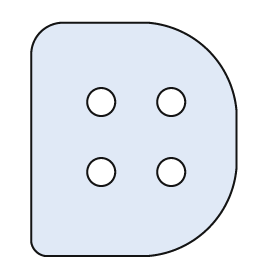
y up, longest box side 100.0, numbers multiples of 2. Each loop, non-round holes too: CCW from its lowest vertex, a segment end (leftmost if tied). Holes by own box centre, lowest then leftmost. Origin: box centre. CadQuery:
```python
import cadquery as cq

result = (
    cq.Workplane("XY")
    .moveTo(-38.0, -50.0)
    .lineTo(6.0, -50.0)
    .threePointArc((32.0, -38.0), (44.0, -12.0))
    .lineTo(44.0, 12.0)
    .threePointArc((32.0, 38.0), (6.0, 50.0))
    .lineTo(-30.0, 50.0)
    .threePointArc((-40.0, 46.0), (-44.0, 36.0))
    .lineTo(-44.0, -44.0)
    .threePointArc((-42.0, -48.0), (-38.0, -50.0))
    .close()
    .moveTo(-14.0, -14.0)
    .circle(6.0)
    .moveTo(16.0, -14.0)
    .circle(6.0)
    .moveTo(-14.0, 16.0)
    .circle(6.0)
    .moveTo(16.0, 16.0)
    .circle(6.0)
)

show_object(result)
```